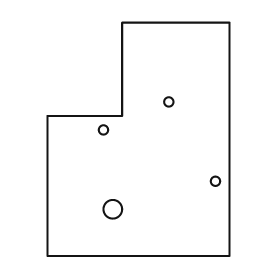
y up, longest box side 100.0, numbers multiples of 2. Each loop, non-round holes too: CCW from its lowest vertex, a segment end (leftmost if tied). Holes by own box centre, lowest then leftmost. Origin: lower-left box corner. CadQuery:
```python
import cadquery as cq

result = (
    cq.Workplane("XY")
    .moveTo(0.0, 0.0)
    .lineTo(78.0, 0.0)
    .lineTo(78.0, 100.0)
    .lineTo(32.0, 100.0)
    .lineTo(32.0, 60.0)
    .lineTo(0.0, 60.0)
    .close()
    .moveTo(28.0, 20.0)
    .circle(4.0)
    .moveTo(72.0, 32.0)
    .circle(2.0)
    .moveTo(24.0, 54.0)
    .circle(2.0)
    .moveTo(52.0, 66.0)
    .circle(2.0)
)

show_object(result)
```